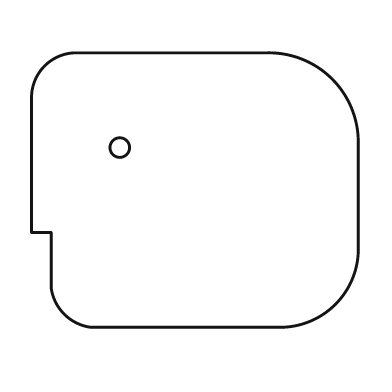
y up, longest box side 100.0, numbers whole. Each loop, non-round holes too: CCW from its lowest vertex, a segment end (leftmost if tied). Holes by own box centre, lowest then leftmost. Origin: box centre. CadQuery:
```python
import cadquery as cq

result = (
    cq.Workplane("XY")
    .moveTo(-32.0, -42.0)
    .lineTo(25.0, -42.0)
    .threePointArc((43.0, -35.0), (50.0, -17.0))
    .lineTo(50.0, 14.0)
    .threePointArc((42.0, 34.0), (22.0, 42.0))
    .lineTo(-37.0, 42.0)
    .threePointArc((-46.0, 38.0), (-50.0, 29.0))
    .lineTo(-50.0, -13.0)
    .lineTo(-44.0, -13.0)
    .lineTo(-44.0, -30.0)
    .threePointArc((-40.0, -38.0), (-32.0, -42.0))
    .close()
    .moveTo(-23.0, 13.0)
    .circle(3.0)
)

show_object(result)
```